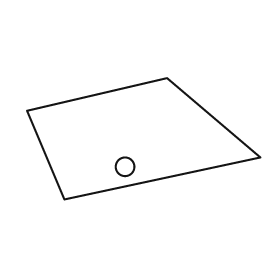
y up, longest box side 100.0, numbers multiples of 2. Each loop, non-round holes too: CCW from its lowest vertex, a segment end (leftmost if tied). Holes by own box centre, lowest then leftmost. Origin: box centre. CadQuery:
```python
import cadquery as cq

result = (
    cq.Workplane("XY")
    .moveTo(-34.0, -26.0)
    .lineTo(50.0, -8.0)
    .lineTo(10.0, 26.0)
    .lineTo(-50.0, 12.0)
    .close()
    .moveTo(-8.0, -12.0)
    .circle(4.0)
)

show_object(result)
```